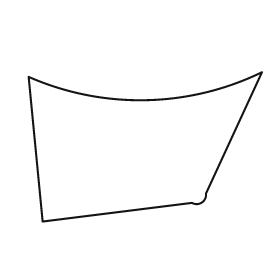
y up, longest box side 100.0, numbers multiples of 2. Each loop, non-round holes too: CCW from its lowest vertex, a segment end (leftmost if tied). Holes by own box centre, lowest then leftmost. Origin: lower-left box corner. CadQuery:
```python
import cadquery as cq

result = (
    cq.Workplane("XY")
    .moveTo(6.0, 0.0)
    .lineTo(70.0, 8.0)
    .threePointArc((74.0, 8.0), (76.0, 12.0))
    .lineTo(100.0, 64.0)
    .threePointArc((50.0, 52.0), (0.0, 62.0))
    .close()
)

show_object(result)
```